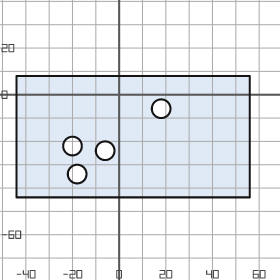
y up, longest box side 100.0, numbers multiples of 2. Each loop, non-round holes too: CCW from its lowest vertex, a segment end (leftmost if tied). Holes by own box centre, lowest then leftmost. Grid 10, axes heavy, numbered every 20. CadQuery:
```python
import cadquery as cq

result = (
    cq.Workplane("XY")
    .moveTo(-44.0, -44.0)
    .lineTo(56.0, -44.0)
    .lineTo(56.0, 8.0)
    .lineTo(-44.0, 8.0)
    .close()
    .moveTo(-18.0, -34.0)
    .circle(4.0)
    .moveTo(-6.0, -24.0)
    .circle(4.0)
    .moveTo(-20.0, -22.0)
    .circle(4.0)
    .moveTo(18.0, -6.0)
    .circle(4.0)
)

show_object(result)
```